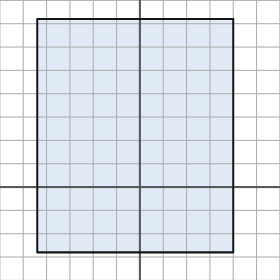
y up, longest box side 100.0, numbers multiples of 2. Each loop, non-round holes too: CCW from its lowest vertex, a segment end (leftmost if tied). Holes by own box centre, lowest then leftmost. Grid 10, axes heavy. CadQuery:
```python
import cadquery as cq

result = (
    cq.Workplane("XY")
    .moveTo(-44.0, -28.0)
    .lineTo(40.0, -28.0)
    .lineTo(40.0, 72.0)
    .lineTo(-44.0, 72.0)
    .close()
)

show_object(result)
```